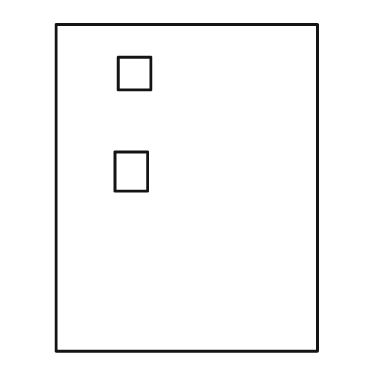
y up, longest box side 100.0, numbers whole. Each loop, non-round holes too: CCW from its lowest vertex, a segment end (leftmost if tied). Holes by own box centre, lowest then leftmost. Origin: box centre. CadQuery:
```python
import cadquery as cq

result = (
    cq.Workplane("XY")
    .moveTo(-40.0, -50.0)
    .lineTo(40.0, -50.0)
    .lineTo(40.0, 50.0)
    .lineTo(-40.0, 50.0)
    .close()
    .moveTo(-22.0, -1.0)
    .lineTo(-12.0, -1.0)
    .lineTo(-12.0, 11.0)
    .lineTo(-22.0, 11.0)
    .close()
    .moveTo(-21.0, 30.0)
    .lineTo(-11.0, 30.0)
    .lineTo(-11.0, 40.0)
    .lineTo(-21.0, 40.0)
    .close()
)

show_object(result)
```